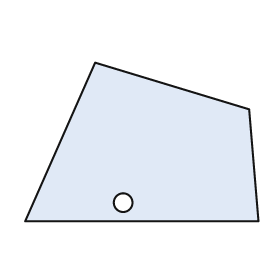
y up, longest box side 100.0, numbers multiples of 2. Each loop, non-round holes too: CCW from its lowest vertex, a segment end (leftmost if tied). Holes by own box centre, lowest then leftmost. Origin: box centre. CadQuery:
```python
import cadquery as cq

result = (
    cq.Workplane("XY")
    .moveTo(-50.0, -34.0)
    .lineTo(50.0, -34.0)
    .lineTo(46.0, 14.0)
    .lineTo(-20.0, 34.0)
    .close()
    .moveTo(-8.0, -26.0)
    .circle(4.0)
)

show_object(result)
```